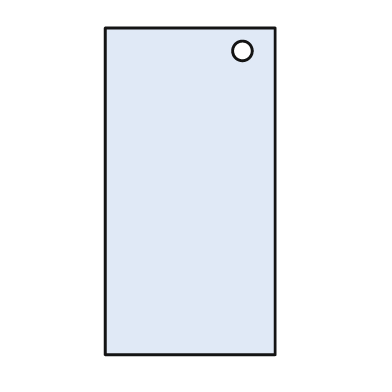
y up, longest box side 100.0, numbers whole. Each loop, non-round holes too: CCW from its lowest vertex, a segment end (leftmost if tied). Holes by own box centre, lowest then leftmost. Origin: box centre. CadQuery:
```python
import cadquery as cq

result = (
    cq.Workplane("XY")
    .moveTo(-26.0, -50.0)
    .lineTo(26.0, -50.0)
    .lineTo(26.0, 50.0)
    .lineTo(-26.0, 50.0)
    .close()
    .moveTo(16.0, 43.0)
    .circle(3.0)
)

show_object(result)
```